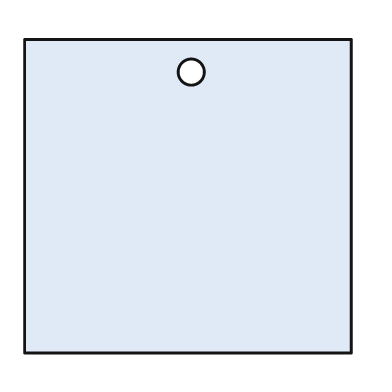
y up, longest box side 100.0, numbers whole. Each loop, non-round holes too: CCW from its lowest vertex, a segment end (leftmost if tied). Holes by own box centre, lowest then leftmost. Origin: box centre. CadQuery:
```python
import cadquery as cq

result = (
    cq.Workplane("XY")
    .moveTo(-50.0, -48.0)
    .lineTo(50.0, -48.0)
    .lineTo(50.0, 48.0)
    .lineTo(-50.0, 48.0)
    .close()
    .moveTo(1.0, 38.0)
    .circle(4.0)
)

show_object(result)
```